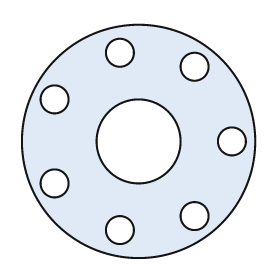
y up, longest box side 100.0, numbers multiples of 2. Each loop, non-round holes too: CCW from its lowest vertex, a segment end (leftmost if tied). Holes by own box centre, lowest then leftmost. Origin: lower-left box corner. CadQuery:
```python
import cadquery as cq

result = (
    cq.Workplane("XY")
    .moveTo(50.0, 50.0)
    .circle(50.0)
    .moveTo(42.0, 12.0)
    .circle(6.0)
    .moveTo(74.0, 18.0)
    .circle(6.0)
    .moveTo(14.0, 32.0)
    .circle(6.0)
    .moveTo(50.0, 50.0)
    .circle(18.0)
    .moveTo(90.0, 50.0)
    .circle(6.0)
    .moveTo(14.0, 68.0)
    .circle(6.0)
    .moveTo(74.0, 82.0)
    .circle(6.0)
    .moveTo(42.0, 88.0)
    .circle(6.0)
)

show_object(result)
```